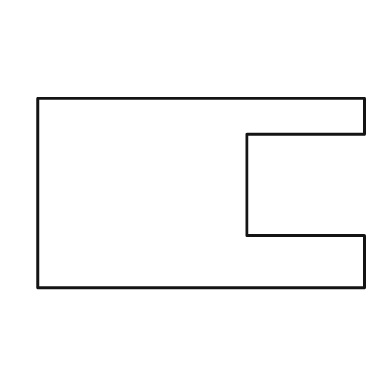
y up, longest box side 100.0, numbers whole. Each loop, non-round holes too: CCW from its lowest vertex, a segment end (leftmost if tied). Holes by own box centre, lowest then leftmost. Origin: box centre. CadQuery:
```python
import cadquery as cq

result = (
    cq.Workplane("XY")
    .moveTo(-50.0, -29.0)
    .lineTo(50.0, -29.0)
    .lineTo(50.0, -13.0)
    .lineTo(14.0, -13.0)
    .lineTo(14.0, 18.0)
    .lineTo(50.0, 18.0)
    .lineTo(50.0, 29.0)
    .lineTo(-50.0, 29.0)
    .close()
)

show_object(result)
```